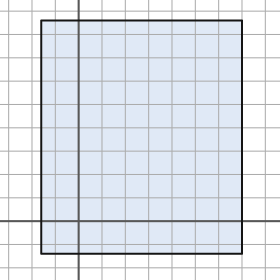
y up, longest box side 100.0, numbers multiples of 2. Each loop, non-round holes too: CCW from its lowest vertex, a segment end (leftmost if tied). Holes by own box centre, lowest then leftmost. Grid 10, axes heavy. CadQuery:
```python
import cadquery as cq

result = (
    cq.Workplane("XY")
    .moveTo(-16.0, -14.0)
    .lineTo(70.0, -14.0)
    .lineTo(70.0, 86.0)
    .lineTo(-16.0, 86.0)
    .close()
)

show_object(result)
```